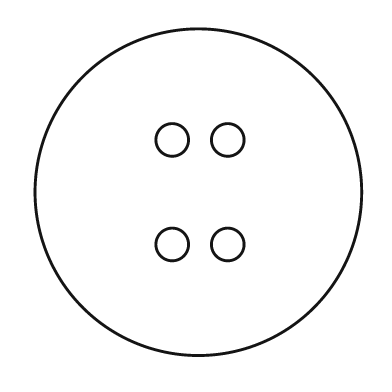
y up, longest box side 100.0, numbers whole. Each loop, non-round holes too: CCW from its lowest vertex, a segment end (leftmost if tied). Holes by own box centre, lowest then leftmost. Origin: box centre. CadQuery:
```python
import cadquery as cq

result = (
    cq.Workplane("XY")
    .moveTo(0.0, 0.0)
    .circle(50.0)
    .moveTo(-8.0, -16.0)
    .circle(5.0)
    .moveTo(9.0, -16.0)
    .circle(5.0)
    .moveTo(-8.0, 16.0)
    .circle(5.0)
    .moveTo(9.0, 16.0)
    .circle(5.0)
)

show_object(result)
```